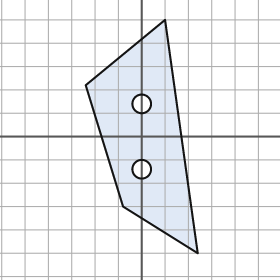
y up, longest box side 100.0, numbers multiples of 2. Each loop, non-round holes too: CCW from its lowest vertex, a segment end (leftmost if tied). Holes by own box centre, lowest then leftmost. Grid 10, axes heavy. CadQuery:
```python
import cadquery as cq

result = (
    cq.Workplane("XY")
    .moveTo(24.0, -50.0)
    .lineTo(10.0, 50.0)
    .lineTo(-24.0, 22.0)
    .lineTo(-8.0, -30.0)
    .close()
    .moveTo(0.0, -14.0)
    .circle(4.0)
    .moveTo(0.0, 14.0)
    .circle(4.0)
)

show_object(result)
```